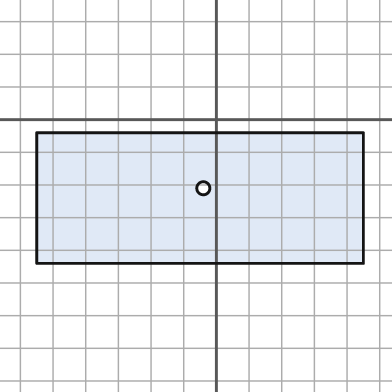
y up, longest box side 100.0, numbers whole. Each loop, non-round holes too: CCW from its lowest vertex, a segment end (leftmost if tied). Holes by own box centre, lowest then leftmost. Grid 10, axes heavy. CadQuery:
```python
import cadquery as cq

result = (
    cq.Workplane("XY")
    .moveTo(-55.0, -44.0)
    .lineTo(45.0, -44.0)
    .lineTo(45.0, -4.0)
    .lineTo(-55.0, -4.0)
    .close()
    .moveTo(-4.0, -21.0)
    .circle(2.0)
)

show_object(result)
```